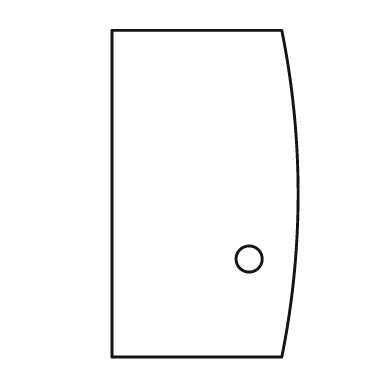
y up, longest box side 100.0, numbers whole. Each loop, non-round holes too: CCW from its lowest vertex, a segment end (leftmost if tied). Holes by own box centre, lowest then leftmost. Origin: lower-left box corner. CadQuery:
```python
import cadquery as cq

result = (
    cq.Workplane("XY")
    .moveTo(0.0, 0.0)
    .lineTo(52.0, 0.0)
    .threePointArc((57.0, 50.0), (52.0, 100.0))
    .lineTo(0.0, 100.0)
    .close()
    .moveTo(42.0, 30.0)
    .circle(4.0)
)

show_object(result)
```